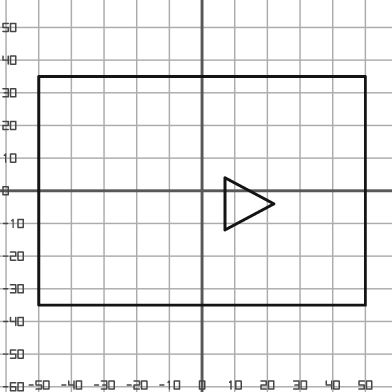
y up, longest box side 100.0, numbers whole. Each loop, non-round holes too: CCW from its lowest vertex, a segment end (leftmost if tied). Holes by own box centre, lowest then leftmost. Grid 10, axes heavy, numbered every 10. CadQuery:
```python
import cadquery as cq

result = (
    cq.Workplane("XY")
    .moveTo(-50.0, -35.0)
    .lineTo(50.0, -35.0)
    .lineTo(50.0, 35.0)
    .lineTo(-50.0, 35.0)
    .close()
    .moveTo(7.0, -12.0)
    .lineTo(22.0, -4.0)
    .lineTo(7.0, 4.0)
    .close()
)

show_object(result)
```